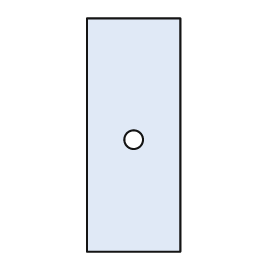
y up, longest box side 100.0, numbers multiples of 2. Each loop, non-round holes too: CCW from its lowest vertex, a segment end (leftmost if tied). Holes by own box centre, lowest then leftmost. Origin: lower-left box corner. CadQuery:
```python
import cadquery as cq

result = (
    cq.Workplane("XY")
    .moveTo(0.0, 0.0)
    .lineTo(40.0, 0.0)
    .lineTo(40.0, 100.0)
    .lineTo(0.0, 100.0)
    .close()
    .moveTo(20.0, 48.0)
    .circle(4.0)
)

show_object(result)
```